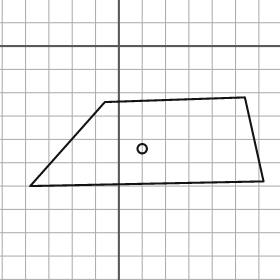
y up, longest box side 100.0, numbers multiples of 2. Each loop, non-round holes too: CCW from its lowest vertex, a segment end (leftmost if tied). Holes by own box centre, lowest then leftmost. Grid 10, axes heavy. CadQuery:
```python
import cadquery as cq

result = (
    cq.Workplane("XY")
    .moveTo(-38.0, -60.0)
    .lineTo(62.0, -58.0)
    .lineTo(54.0, -22.0)
    .lineTo(-6.0, -24.0)
    .close()
    .moveTo(10.0, -44.0)
    .circle(2.0)
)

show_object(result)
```